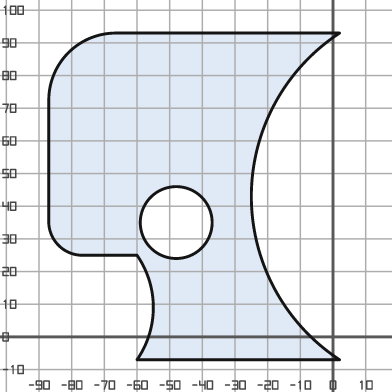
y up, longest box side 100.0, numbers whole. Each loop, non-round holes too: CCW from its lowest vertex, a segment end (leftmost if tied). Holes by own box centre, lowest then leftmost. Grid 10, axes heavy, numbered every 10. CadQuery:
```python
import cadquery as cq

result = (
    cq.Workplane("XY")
    .moveTo(-60.0, -7.0)
    .lineTo(2.0, -7.0)
    .threePointArc((-25.0, 43.0), (2.0, 93.0))
    .lineTo(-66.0, 93.0)
    .threePointArc((-81.0, 87.0), (-87.0, 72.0))
    .lineTo(-87.0, 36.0)
    .threePointArc((-84.0, 28.0), (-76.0, 25.0))
    .lineTo(-60.0, 25.0)
    .threePointArc((-55.0, 9.0), (-60.0, -7.0))
    .close()
    .moveTo(-48.0, 35.0)
    .circle(11.0)
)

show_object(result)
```